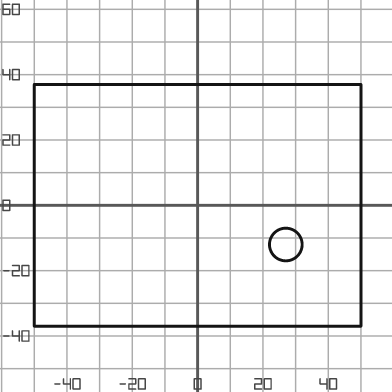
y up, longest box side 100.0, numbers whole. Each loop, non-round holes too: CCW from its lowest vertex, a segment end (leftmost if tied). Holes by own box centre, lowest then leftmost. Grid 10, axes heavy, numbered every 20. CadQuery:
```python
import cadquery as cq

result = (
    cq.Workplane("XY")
    .moveTo(-50.0, -37.0)
    .lineTo(50.0, -37.0)
    .lineTo(50.0, 37.0)
    .lineTo(-50.0, 37.0)
    .close()
    .moveTo(27.0, -12.0)
    .circle(5.0)
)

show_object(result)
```